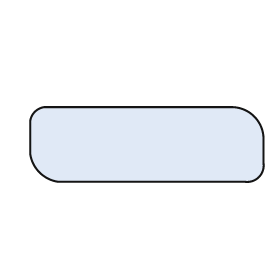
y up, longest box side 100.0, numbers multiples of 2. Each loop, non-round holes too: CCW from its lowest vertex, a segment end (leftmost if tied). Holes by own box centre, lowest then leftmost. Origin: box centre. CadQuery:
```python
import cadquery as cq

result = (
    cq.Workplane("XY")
    .moveTo(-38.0, -16.0)
    .lineTo(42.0, -16.0)
    .threePointArc((48.0, -14.0), (50.0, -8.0))
    .lineTo(50.0, 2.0)
    .threePointArc((46.0, 12.0), (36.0, 16.0))
    .lineTo(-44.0, 16.0)
    .threePointArc((-48.0, 14.0), (-50.0, 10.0))
    .lineTo(-50.0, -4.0)
    .threePointArc((-46.0, -12.0), (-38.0, -16.0))
    .close()
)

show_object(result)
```